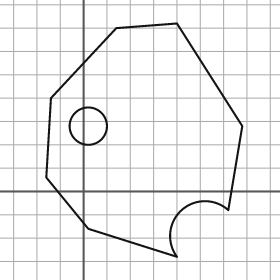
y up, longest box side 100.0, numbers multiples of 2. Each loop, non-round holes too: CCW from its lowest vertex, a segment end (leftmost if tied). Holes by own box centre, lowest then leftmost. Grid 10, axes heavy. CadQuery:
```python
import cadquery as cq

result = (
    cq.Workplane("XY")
    .moveTo(40.0, -28.0)
    .threePointArc((42.0, -8.0), (62.0, -8.0))
    .lineTo(68.0, 28.0)
    .lineTo(40.0, 72.0)
    .lineTo(14.0, 70.0)
    .lineTo(-14.0, 40.0)
    .lineTo(-16.0, 6.0)
    .lineTo(2.0, -16.0)
    .close()
    .moveTo(2.0, 28.0)
    .circle(8.0)
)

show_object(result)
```